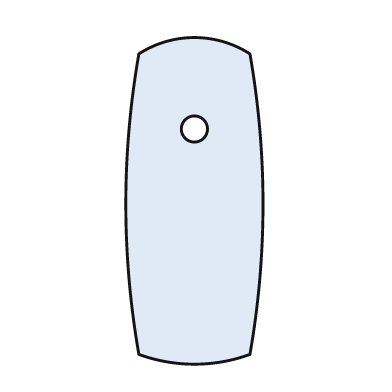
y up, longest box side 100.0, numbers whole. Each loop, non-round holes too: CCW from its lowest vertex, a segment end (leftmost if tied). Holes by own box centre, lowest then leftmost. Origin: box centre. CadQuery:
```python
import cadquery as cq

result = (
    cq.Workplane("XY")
    .moveTo(-17.0, -47.0)
    .threePointArc((0.0, -50.0), (17.0, -47.0))
    .threePointArc((21.0, -1.0), (17.0, 45.0))
    .threePointArc((0.0, 50.0), (-17.0, 45.0))
    .threePointArc((-21.0, -1.0), (-17.0, -47.0))
    .close()
    .moveTo(0.0, 22.0)
    .circle(4.0)
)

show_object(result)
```